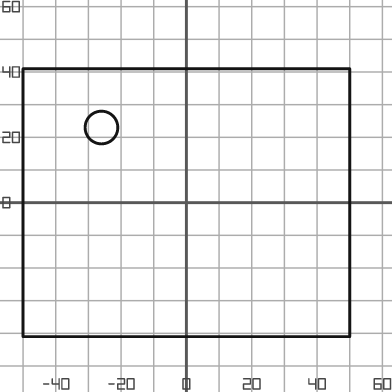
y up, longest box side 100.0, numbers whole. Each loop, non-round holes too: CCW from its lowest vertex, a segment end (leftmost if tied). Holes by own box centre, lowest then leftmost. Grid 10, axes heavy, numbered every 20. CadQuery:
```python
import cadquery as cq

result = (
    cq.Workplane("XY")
    .moveTo(-50.0, -41.0)
    .lineTo(50.0, -41.0)
    .lineTo(50.0, 41.0)
    .lineTo(-50.0, 41.0)
    .close()
    .moveTo(-26.0, 23.0)
    .circle(5.0)
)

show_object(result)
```